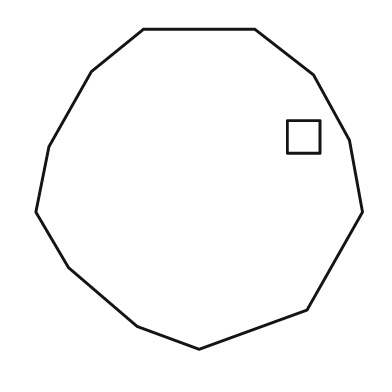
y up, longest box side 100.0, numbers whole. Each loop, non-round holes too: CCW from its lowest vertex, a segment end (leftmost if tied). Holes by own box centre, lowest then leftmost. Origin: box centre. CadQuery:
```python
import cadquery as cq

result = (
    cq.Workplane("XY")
    .moveTo(0.0, -49.0)
    .lineTo(33.0, -37.0)
    .lineTo(50.0, -7.0)
    .lineTo(46.0, 15.0)
    .lineTo(35.0, 35.0)
    .lineTo(17.0, 49.0)
    .lineTo(-17.0, 49.0)
    .lineTo(-33.0, 36.0)
    .lineTo(-46.0, 13.0)
    .lineTo(-50.0, -7.0)
    .lineTo(-40.0, -24.0)
    .lineTo(-19.0, -42.0)
    .close()
    .moveTo(27.0, 11.0)
    .lineTo(37.0, 11.0)
    .lineTo(37.0, 21.0)
    .lineTo(27.0, 21.0)
    .close()
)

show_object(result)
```